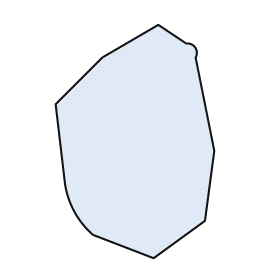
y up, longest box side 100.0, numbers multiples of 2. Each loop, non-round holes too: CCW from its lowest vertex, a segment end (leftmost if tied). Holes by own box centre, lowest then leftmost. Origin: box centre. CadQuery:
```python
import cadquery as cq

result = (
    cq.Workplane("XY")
    .moveTo(8.0, -50.0)
    .lineTo(30.0, -34.0)
    .lineTo(34.0, -4.0)
    .lineTo(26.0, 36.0)
    .threePointArc((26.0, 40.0), (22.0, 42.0))
    .lineTo(10.0, 50.0)
    .lineTo(-14.0, 36.0)
    .lineTo(-34.0, 16.0)
    .lineTo(-30.0, -18.0)
    .threePointArc((-26.0, -30.0), (-18.0, -40.0))
    .close()
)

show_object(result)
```